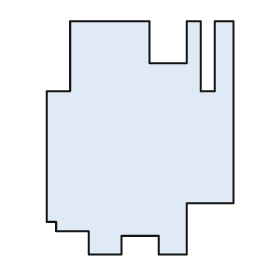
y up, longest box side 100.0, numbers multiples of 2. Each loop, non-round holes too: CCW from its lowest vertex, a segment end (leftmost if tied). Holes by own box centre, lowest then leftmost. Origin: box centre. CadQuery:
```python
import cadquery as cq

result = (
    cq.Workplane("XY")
    .moveTo(-22.0, -50.0)
    .lineTo(-8.0, -50.0)
    .lineTo(-8.0, -42.0)
    .lineTo(8.0, -42.0)
    .lineTo(8.0, -50.0)
    .lineTo(20.0, -50.0)
    .lineTo(20.0, -28.0)
    .lineTo(40.0, -28.0)
    .lineTo(40.0, 50.0)
    .lineTo(32.0, 50.0)
    .lineTo(32.0, 20.0)
    .lineTo(26.0, 20.0)
    .lineTo(26.0, 50.0)
    .lineTo(20.0, 50.0)
    .lineTo(20.0, 32.0)
    .lineTo(4.0, 32.0)
    .lineTo(4.0, 50.0)
    .lineTo(-30.0, 50.0)
    .lineTo(-30.0, 20.0)
    .lineTo(-40.0, 20.0)
    .lineTo(-40.0, -36.0)
    .lineTo(-36.0, -36.0)
    .lineTo(-36.0, -40.0)
    .lineTo(-22.0, -40.0)
    .close()
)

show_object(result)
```